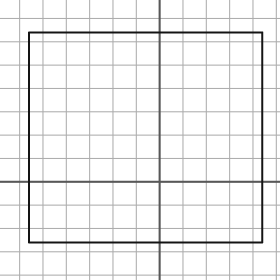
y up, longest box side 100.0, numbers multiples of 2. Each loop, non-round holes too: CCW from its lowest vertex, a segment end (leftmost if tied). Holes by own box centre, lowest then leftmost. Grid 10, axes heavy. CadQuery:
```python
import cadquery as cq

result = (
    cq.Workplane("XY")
    .moveTo(-56.0, -26.0)
    .lineTo(44.0, -26.0)
    .lineTo(44.0, 64.0)
    .lineTo(-56.0, 64.0)
    .close()
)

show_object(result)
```